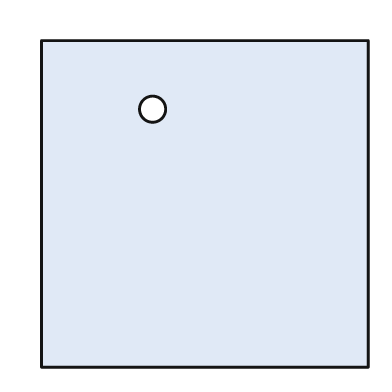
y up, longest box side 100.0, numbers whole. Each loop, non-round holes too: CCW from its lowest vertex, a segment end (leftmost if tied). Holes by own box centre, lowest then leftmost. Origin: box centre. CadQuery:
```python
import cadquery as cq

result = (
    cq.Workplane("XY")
    .moveTo(-50.0, -50.0)
    .lineTo(50.0, -50.0)
    .lineTo(50.0, 50.0)
    .lineTo(-50.0, 50.0)
    .close()
    .moveTo(-16.0, 29.0)
    .circle(4.0)
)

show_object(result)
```